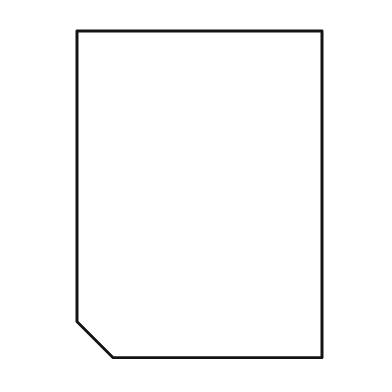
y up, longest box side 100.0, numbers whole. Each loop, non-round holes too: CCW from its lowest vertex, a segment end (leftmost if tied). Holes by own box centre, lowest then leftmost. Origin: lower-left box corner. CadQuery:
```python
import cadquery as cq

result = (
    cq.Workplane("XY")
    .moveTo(11.0, 0.0)
    .lineTo(75.0, 0.0)
    .lineTo(75.0, 100.0)
    .lineTo(0.0, 100.0)
    .lineTo(0.0, 11.0)
    .close()
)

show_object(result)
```